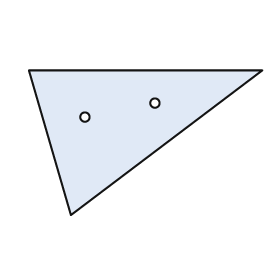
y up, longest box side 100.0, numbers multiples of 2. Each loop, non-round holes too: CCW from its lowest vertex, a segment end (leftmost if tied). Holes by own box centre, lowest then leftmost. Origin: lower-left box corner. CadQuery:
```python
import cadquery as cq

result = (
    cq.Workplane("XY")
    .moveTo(18.0, 0.0)
    .lineTo(100.0, 62.0)
    .lineTo(0.0, 62.0)
    .close()
    .moveTo(24.0, 42.0)
    .circle(2.0)
    .moveTo(54.0, 48.0)
    .circle(2.0)
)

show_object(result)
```